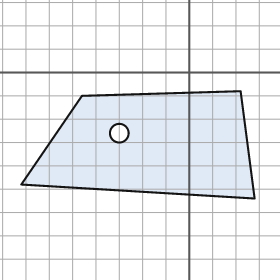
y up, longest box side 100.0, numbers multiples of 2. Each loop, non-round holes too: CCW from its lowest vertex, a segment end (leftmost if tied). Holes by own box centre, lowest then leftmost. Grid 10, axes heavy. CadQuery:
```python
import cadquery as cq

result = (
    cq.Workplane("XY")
    .moveTo(28.0, -54.0)
    .lineTo(22.0, -8.0)
    .lineTo(-46.0, -10.0)
    .lineTo(-72.0, -48.0)
    .close()
    .moveTo(-30.0, -26.0)
    .circle(4.0)
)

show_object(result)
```